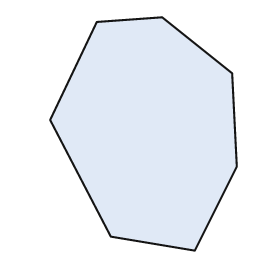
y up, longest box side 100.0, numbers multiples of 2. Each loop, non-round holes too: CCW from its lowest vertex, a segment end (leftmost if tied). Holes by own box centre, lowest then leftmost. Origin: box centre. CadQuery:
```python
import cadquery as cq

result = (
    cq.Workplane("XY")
    .moveTo(22.0, -50.0)
    .lineTo(40.0, -14.0)
    .lineTo(38.0, 26.0)
    .lineTo(8.0, 50.0)
    .lineTo(-20.0, 48.0)
    .lineTo(-40.0, 6.0)
    .lineTo(-14.0, -44.0)
    .close()
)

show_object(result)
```